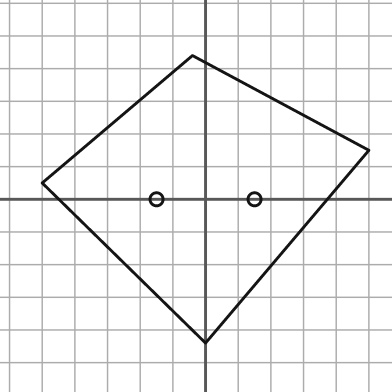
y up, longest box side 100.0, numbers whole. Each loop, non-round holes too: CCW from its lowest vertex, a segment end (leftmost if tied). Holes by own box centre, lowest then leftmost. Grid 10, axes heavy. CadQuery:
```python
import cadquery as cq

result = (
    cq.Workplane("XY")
    .moveTo(0.0, -44.0)
    .lineTo(50.0, 15.0)
    .lineTo(-4.0, 44.0)
    .lineTo(-50.0, 5.0)
    .close()
    .moveTo(-15.0, 0.0)
    .circle(2.0)
    .moveTo(15.0, 0.0)
    .circle(2.0)
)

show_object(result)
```